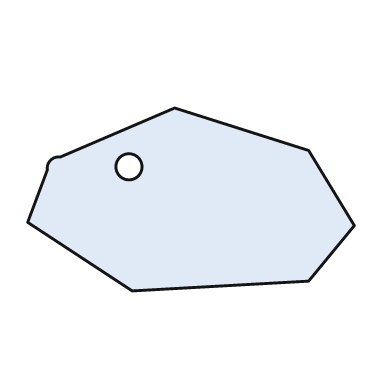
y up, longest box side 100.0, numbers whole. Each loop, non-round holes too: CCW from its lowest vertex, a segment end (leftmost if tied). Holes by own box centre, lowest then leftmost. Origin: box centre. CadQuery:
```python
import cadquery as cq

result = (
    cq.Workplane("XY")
    .moveTo(-18.0, -28.0)
    .lineTo(36.0, -25.0)
    .lineTo(50.0, -8.0)
    .lineTo(36.0, 15.0)
    .lineTo(-5.0, 28.0)
    .lineTo(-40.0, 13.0)
    .threePointArc((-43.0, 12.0), (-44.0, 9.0))
    .lineTo(-50.0, -7.0)
    .close()
    .moveTo(-19.0, 10.0)
    .circle(4.0)
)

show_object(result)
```